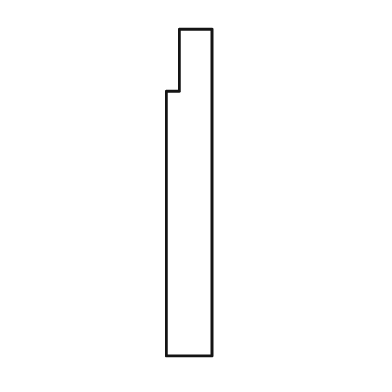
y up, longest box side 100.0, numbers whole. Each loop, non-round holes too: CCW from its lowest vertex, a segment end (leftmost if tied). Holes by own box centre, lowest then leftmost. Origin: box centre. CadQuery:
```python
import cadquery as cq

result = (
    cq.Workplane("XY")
    .moveTo(-7.0, -50.0)
    .lineTo(7.0, -50.0)
    .lineTo(7.0, 50.0)
    .lineTo(-3.0, 50.0)
    .lineTo(-3.0, 31.0)
    .lineTo(-7.0, 31.0)
    .close()
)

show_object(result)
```